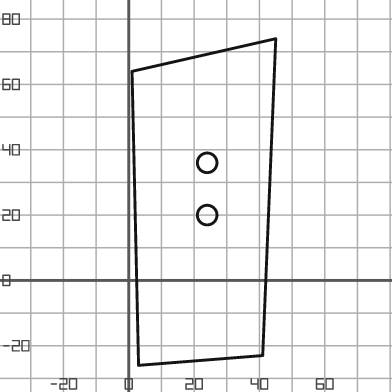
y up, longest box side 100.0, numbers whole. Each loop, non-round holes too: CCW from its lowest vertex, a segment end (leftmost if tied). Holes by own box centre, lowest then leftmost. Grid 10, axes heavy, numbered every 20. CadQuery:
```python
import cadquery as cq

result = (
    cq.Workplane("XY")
    .moveTo(3.0, -26.0)
    .lineTo(41.0, -23.0)
    .lineTo(45.0, 74.0)
    .lineTo(1.0, 64.0)
    .close()
    .moveTo(24.0, 20.0)
    .circle(3.0)
    .moveTo(24.0, 36.0)
    .circle(3.0)
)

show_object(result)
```